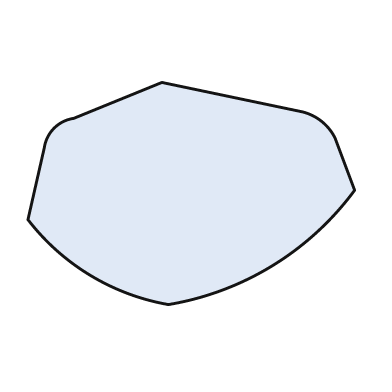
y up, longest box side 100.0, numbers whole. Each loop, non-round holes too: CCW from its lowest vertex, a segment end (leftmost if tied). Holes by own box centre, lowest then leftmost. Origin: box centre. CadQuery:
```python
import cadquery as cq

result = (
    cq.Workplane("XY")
    .moveTo(-7.0, -34.0)
    .threePointArc((25.0, -22.0), (50.0, 1.0))
    .lineTo(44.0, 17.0)
    .threePointArc((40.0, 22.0), (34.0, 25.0))
    .lineTo(-9.0, 34.0)
    .lineTo(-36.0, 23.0)
    .threePointArc((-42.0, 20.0), (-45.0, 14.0))
    .lineTo(-50.0, -8.0)
    .threePointArc((-31.0, -25.0), (-7.0, -34.0))
    .close()
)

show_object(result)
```